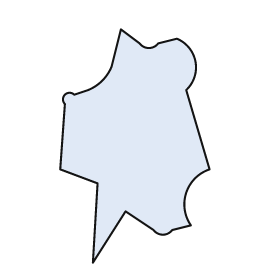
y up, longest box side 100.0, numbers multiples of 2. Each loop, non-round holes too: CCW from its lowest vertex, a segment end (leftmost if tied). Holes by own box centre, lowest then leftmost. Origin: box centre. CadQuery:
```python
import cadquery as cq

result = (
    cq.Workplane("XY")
    .moveTo(-18.0, -50.0)
    .lineTo(-4.0, -28.0)
    .lineTo(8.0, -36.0)
    .threePointArc((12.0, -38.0), (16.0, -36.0))
    .lineTo(24.0, -34.0)
    .threePointArc((22.0, -20.0), (32.0, -10.0))
    .lineTo(22.0, 24.0)
    .threePointArc((26.0, 36.0), (18.0, 46.0))
    .lineTo(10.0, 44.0)
    .threePointArc((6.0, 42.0), (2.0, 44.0))
    .lineTo(-6.0, 50.0)
    .lineTo(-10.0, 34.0)
    .threePointArc((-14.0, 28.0), (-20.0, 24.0))
    .lineTo(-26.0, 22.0)
    .threePointArc((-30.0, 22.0), (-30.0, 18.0))
    .lineTo(-32.0, -10.0)
    .lineTo(-16.0, -16.0)
    .close()
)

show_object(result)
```